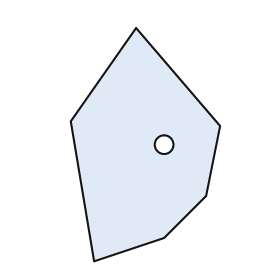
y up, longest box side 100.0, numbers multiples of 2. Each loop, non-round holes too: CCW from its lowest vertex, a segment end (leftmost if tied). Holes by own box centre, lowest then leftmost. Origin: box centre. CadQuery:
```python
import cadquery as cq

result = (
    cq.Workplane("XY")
    .moveTo(-22.0, -50.0)
    .lineTo(8.0, -40.0)
    .lineTo(26.0, -22.0)
    .lineTo(32.0, 8.0)
    .lineTo(-4.0, 50.0)
    .lineTo(-32.0, 10.0)
    .close()
    .moveTo(8.0, 0.0)
    .circle(4.0)
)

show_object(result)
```